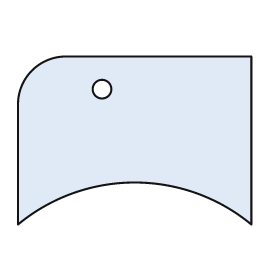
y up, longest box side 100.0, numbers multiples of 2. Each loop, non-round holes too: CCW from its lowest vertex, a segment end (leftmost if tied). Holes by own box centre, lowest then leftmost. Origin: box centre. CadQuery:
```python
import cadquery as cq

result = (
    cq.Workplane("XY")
    .moveTo(-50.0, -36.0)
    .threePointArc((0.0, -18.0), (50.0, -36.0))
    .lineTo(50.0, 36.0)
    .lineTo(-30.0, 36.0)
    .threePointArc((-44.0, 30.0), (-50.0, 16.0))
    .close()
    .moveTo(-14.0, 22.0)
    .circle(4.0)
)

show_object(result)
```